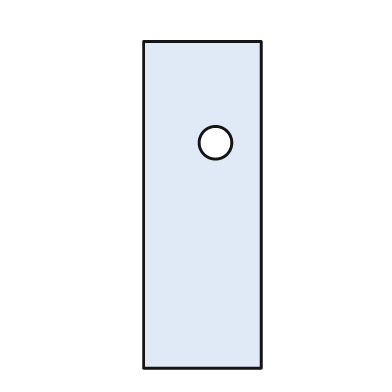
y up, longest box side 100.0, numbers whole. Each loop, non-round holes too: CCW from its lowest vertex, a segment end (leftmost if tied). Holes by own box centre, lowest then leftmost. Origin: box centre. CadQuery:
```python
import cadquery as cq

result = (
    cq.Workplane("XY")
    .moveTo(-18.0, -50.0)
    .lineTo(18.0, -50.0)
    .lineTo(18.0, 50.0)
    .lineTo(-18.0, 50.0)
    .close()
    .moveTo(4.0, 19.0)
    .circle(5.0)
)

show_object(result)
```